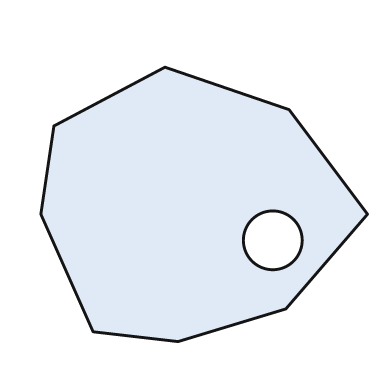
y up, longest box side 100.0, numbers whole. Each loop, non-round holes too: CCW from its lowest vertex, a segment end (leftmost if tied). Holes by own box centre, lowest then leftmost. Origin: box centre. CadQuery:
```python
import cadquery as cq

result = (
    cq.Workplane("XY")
    .moveTo(-8.0, -42.0)
    .lineTo(25.0, -32.0)
    .lineTo(50.0, -3.0)
    .lineTo(26.0, 29.0)
    .lineTo(-12.0, 42.0)
    .lineTo(-46.0, 24.0)
    .lineTo(-50.0, -3.0)
    .lineTo(-34.0, -39.0)
    .close()
    .moveTo(21.0, -11.0)
    .circle(9.0)
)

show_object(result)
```